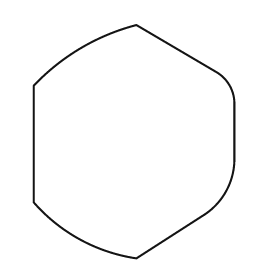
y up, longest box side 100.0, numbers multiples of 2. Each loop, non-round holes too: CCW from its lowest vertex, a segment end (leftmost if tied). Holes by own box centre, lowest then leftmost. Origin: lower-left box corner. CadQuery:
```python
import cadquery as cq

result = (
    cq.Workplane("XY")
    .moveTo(44.0, 0.0)
    .lineTo(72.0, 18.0)
    .threePointArc((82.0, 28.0), (86.0, 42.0))
    .lineTo(86.0, 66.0)
    .threePointArc((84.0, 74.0), (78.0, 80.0))
    .lineTo(44.0, 100.0)
    .threePointArc((20.0, 90.0), (0.0, 74.0))
    .lineTo(0.0, 24.0)
    .threePointArc((20.0, 8.0), (44.0, 0.0))
    .close()
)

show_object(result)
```